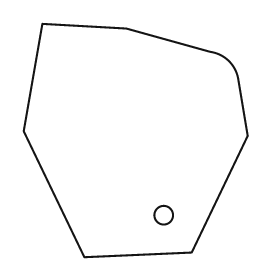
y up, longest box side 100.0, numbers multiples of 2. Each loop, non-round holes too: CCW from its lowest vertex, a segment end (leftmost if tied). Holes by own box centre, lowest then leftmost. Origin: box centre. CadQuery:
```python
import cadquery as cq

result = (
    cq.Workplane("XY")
    .moveTo(-22.0, -50.0)
    .lineTo(24.0, -48.0)
    .lineTo(48.0, 2.0)
    .lineTo(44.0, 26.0)
    .threePointArc((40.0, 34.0), (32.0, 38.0))
    .lineTo(-4.0, 48.0)
    .lineTo(-40.0, 50.0)
    .lineTo(-48.0, 4.0)
    .close()
    .moveTo(12.0, -32.0)
    .circle(4.0)
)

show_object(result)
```